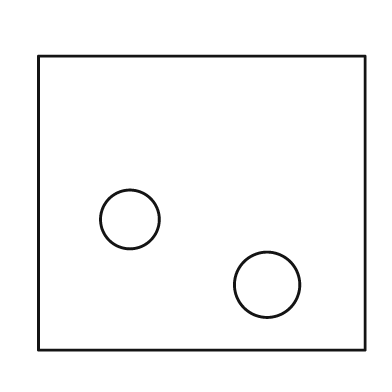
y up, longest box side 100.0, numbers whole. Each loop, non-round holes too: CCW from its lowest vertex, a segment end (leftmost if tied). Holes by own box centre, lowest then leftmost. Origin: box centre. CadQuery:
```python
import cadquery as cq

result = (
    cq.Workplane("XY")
    .moveTo(-50.0, -45.0)
    .lineTo(50.0, -45.0)
    .lineTo(50.0, 45.0)
    .lineTo(-50.0, 45.0)
    .close()
    .moveTo(20.0, -25.0)
    .circle(10.0)
    .moveTo(-22.0, -5.0)
    .circle(9.0)
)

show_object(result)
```